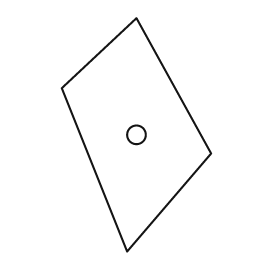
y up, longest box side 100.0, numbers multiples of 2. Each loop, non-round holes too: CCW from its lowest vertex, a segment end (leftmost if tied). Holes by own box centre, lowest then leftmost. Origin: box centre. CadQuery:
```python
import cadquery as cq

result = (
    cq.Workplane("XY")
    .moveTo(-4.0, -50.0)
    .lineTo(32.0, -8.0)
    .lineTo(0.0, 50.0)
    .lineTo(-32.0, 20.0)
    .close()
    .moveTo(0.0, 0.0)
    .circle(4.0)
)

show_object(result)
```